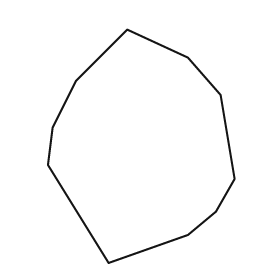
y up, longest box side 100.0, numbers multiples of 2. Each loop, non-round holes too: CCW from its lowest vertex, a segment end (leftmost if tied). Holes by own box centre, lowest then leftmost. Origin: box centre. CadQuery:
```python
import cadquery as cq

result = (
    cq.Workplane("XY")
    .moveTo(-14.0, -50.0)
    .lineTo(20.0, -38.0)
    .lineTo(32.0, -28.0)
    .lineTo(40.0, -14.0)
    .lineTo(34.0, 22.0)
    .lineTo(20.0, 38.0)
    .lineTo(-6.0, 50.0)
    .lineTo(-28.0, 28.0)
    .lineTo(-38.0, 8.0)
    .lineTo(-40.0, -8.0)
    .close()
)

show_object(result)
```